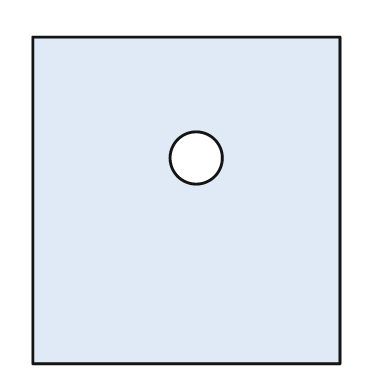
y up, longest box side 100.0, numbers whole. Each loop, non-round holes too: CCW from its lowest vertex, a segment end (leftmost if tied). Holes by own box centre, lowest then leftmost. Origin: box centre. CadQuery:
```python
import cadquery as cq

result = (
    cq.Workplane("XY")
    .moveTo(-47.0, -50.0)
    .lineTo(47.0, -50.0)
    .lineTo(47.0, 50.0)
    .lineTo(-47.0, 50.0)
    .close()
    .moveTo(3.0, 13.0)
    .circle(8.0)
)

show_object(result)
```